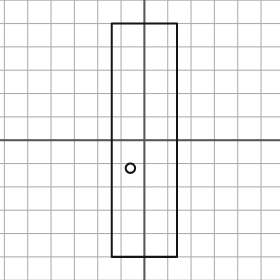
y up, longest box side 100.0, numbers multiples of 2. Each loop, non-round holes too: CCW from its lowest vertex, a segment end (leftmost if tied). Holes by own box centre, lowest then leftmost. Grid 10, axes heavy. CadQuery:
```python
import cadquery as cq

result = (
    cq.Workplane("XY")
    .moveTo(-14.0, -50.0)
    .lineTo(14.0, -50.0)
    .lineTo(14.0, 50.0)
    .lineTo(-14.0, 50.0)
    .close()
    .moveTo(-6.0, -12.0)
    .circle(2.0)
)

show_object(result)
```